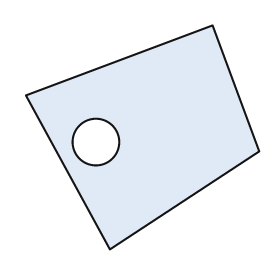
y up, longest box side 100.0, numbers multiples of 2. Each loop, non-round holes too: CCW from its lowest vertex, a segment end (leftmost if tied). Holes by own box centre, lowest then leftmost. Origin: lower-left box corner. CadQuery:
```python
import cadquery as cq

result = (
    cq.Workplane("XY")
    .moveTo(36.0, 0.0)
    .lineTo(100.0, 42.0)
    .lineTo(80.0, 96.0)
    .lineTo(0.0, 66.0)
    .close()
    .moveTo(30.0, 46.0)
    .circle(10.0)
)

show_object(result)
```